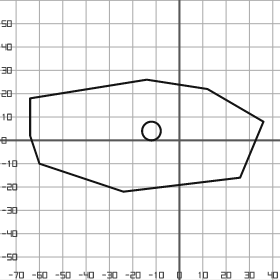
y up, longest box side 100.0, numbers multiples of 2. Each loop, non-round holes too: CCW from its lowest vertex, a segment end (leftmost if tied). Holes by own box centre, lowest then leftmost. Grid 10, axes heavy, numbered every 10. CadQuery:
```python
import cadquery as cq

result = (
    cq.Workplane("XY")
    .moveTo(-24.0, -22.0)
    .lineTo(26.0, -16.0)
    .lineTo(36.0, 8.0)
    .lineTo(12.0, 22.0)
    .lineTo(-14.0, 26.0)
    .lineTo(-64.0, 18.0)
    .lineTo(-64.0, 2.0)
    .lineTo(-60.0, -10.0)
    .close()
    .moveTo(-12.0, 4.0)
    .circle(4.0)
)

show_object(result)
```